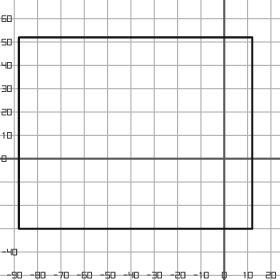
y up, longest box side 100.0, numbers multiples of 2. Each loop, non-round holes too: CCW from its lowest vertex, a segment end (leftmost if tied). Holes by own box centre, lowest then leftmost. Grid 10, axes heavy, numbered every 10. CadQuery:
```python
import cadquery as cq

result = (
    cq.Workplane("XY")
    .moveTo(-88.0, -30.0)
    .lineTo(12.0, -30.0)
    .lineTo(12.0, 52.0)
    .lineTo(-88.0, 52.0)
    .close()
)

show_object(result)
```